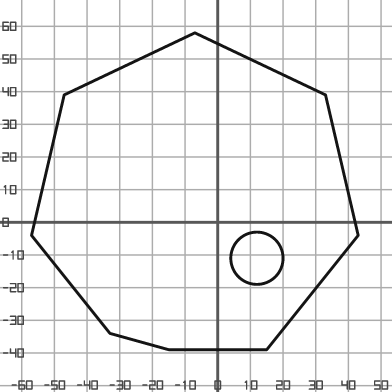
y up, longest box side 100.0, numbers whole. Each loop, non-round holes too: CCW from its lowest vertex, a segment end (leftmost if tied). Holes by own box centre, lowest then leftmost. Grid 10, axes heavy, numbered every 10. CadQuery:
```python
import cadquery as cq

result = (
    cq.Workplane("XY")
    .moveTo(-15.0, -39.0)
    .lineTo(15.0, -39.0)
    .lineTo(43.0, -4.0)
    .lineTo(33.0, 39.0)
    .lineTo(-7.0, 58.0)
    .lineTo(-47.0, 39.0)
    .lineTo(-57.0, -4.0)
    .lineTo(-33.0, -34.0)
    .close()
    .moveTo(12.0, -11.0)
    .circle(8.0)
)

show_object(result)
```